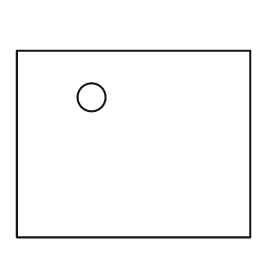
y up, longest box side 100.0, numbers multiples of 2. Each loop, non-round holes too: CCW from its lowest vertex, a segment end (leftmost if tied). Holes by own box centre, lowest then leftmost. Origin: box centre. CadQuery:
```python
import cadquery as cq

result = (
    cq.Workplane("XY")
    .moveTo(-50.0, -40.0)
    .lineTo(50.0, -40.0)
    .lineTo(50.0, 40.0)
    .lineTo(-50.0, 40.0)
    .close()
    .moveTo(-18.0, 20.0)
    .circle(6.0)
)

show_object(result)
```